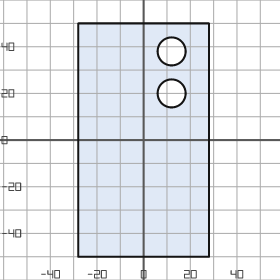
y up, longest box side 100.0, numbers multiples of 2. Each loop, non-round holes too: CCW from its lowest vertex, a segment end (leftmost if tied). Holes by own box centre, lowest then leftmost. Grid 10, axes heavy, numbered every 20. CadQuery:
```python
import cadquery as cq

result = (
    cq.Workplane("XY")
    .moveTo(-28.0, -50.0)
    .lineTo(28.0, -50.0)
    .lineTo(28.0, 50.0)
    .lineTo(-28.0, 50.0)
    .close()
    .moveTo(12.0, 20.0)
    .circle(6.0)
    .moveTo(12.0, 38.0)
    .circle(6.0)
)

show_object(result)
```